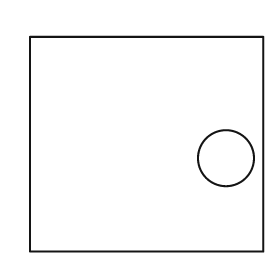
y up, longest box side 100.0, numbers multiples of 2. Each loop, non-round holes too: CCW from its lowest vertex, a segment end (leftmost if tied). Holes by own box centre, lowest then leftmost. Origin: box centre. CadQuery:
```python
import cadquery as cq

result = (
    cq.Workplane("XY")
    .moveTo(-50.0, -46.0)
    .lineTo(50.0, -46.0)
    .lineTo(50.0, 46.0)
    .lineTo(-50.0, 46.0)
    .close()
    .moveTo(34.0, -6.0)
    .circle(12.0)
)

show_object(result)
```